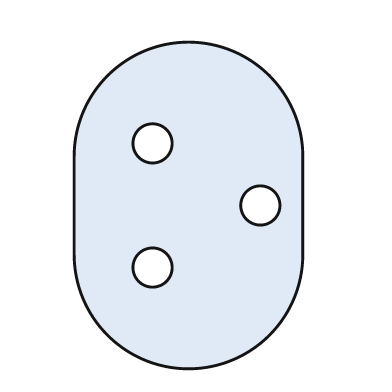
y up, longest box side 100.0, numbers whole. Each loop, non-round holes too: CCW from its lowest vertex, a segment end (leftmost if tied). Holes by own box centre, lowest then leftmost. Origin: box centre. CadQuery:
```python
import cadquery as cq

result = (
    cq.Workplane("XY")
    .moveTo(-35.0, -15.0)
    .threePointArc((0.0, -50.0), (35.0, -15.0))
    .lineTo(35.0, 15.0)
    .threePointArc((0.0, 50.0), (-35.0, 15.0))
    .close()
    .moveTo(-11.0, -19.0)
    .circle(6.0)
    .moveTo(22.0, 0.0)
    .circle(6.0)
    .moveTo(-11.0, 19.0)
    .circle(6.0)
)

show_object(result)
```